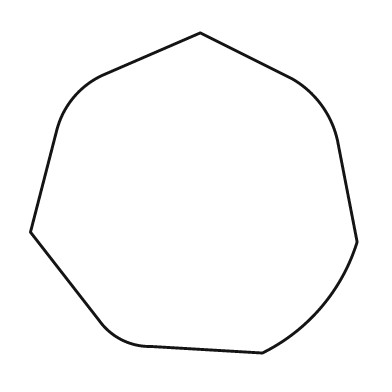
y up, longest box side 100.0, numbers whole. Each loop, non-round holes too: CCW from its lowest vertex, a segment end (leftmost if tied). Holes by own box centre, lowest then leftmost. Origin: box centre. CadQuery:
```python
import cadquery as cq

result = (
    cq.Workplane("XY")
    .moveTo(21.0, -49.0)
    .threePointArc((39.0, -35.0), (50.0, -15.0))
    .lineTo(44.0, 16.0)
    .threePointArc((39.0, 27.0), (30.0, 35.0))
    .lineTo(2.0, 49.0)
    .lineTo(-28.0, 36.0)
    .threePointArc((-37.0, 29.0), (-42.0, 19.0))
    .lineTo(-50.0, -12.0)
    .lineTo(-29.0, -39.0)
    .threePointArc((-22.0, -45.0), (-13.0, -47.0))
    .close()
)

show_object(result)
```